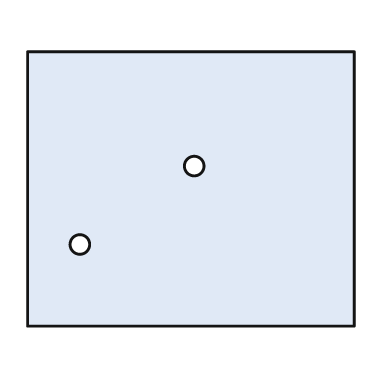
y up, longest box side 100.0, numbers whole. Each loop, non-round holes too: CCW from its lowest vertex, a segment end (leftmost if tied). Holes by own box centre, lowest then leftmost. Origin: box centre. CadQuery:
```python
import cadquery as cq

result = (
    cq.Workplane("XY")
    .moveTo(-50.0, -42.0)
    .lineTo(50.0, -42.0)
    .lineTo(50.0, 42.0)
    .lineTo(-50.0, 42.0)
    .close()
    .moveTo(-34.0, -17.0)
    .circle(3.0)
    .moveTo(1.0, 7.0)
    .circle(3.0)
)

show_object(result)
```